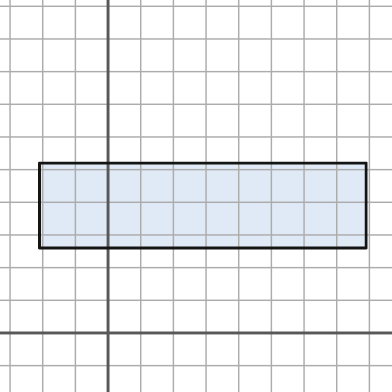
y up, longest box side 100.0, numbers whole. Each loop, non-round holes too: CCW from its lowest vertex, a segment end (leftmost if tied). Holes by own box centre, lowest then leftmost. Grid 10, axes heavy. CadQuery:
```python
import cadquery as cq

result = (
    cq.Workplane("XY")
    .moveTo(-21.0, 26.0)
    .lineTo(79.0, 26.0)
    .lineTo(79.0, 52.0)
    .lineTo(-21.0, 52.0)
    .close()
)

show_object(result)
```